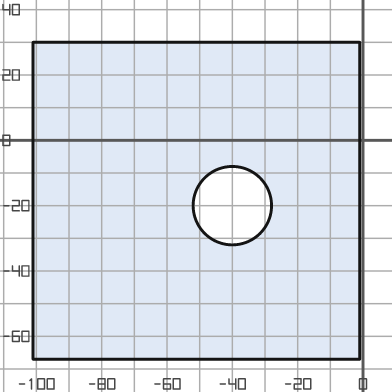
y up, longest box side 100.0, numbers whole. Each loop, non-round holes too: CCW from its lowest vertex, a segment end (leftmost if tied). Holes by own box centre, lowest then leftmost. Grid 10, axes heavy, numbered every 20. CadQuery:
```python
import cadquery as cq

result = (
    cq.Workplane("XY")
    .moveTo(-101.0, -67.0)
    .lineTo(-1.0, -67.0)
    .lineTo(-1.0, 30.0)
    .lineTo(-101.0, 30.0)
    .close()
    .moveTo(-40.0, -20.0)
    .circle(12.0)
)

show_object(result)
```